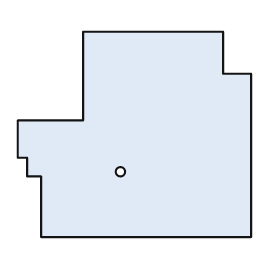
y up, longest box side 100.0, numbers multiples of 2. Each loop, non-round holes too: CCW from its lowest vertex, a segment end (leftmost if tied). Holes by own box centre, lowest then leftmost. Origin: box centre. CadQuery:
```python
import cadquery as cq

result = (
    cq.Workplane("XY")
    .moveTo(-40.0, -44.0)
    .lineTo(50.0, -44.0)
    .lineTo(50.0, 26.0)
    .lineTo(38.0, 26.0)
    .lineTo(38.0, 44.0)
    .lineTo(-22.0, 44.0)
    .lineTo(-22.0, 6.0)
    .lineTo(-50.0, 6.0)
    .lineTo(-50.0, -10.0)
    .lineTo(-46.0, -10.0)
    .lineTo(-46.0, -18.0)
    .lineTo(-40.0, -18.0)
    .close()
    .moveTo(-6.0, -16.0)
    .circle(2.0)
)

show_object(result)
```